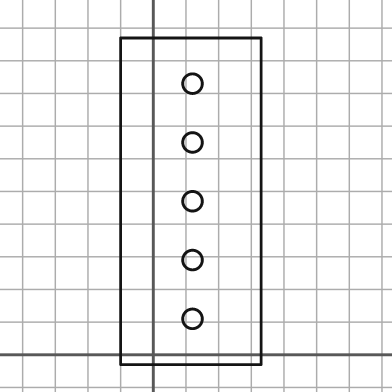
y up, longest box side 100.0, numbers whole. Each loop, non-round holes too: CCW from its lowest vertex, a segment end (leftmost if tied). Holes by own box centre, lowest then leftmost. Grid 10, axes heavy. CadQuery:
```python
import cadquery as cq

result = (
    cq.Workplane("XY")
    .moveTo(-10.0, -3.0)
    .lineTo(33.0, -3.0)
    .lineTo(33.0, 97.0)
    .lineTo(-10.0, 97.0)
    .close()
    .moveTo(12.0, 11.0)
    .circle(3.0)
    .moveTo(12.0, 29.0)
    .circle(3.0)
    .moveTo(12.0, 47.0)
    .circle(3.0)
    .moveTo(12.0, 65.0)
    .circle(3.0)
    .moveTo(12.0, 83.0)
    .circle(3.0)
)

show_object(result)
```